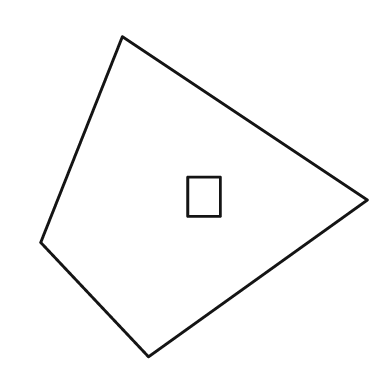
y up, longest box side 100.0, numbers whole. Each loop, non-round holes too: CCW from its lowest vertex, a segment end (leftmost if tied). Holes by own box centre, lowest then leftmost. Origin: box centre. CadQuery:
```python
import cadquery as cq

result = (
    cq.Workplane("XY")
    .moveTo(-17.0, -49.0)
    .lineTo(50.0, -1.0)
    .lineTo(-25.0, 49.0)
    .lineTo(-50.0, -14.0)
    .close()
    .moveTo(-5.0, -6.0)
    .lineTo(5.0, -6.0)
    .lineTo(5.0, 6.0)
    .lineTo(-5.0, 6.0)
    .close()
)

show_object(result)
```